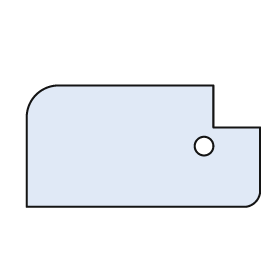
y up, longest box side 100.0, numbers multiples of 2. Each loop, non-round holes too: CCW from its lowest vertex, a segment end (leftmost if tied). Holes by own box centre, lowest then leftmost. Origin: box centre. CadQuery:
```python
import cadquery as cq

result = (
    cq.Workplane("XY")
    .moveTo(-50.0, -26.0)
    .lineTo(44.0, -26.0)
    .threePointArc((48.0, -24.0), (50.0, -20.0))
    .lineTo(50.0, 8.0)
    .lineTo(30.0, 8.0)
    .lineTo(30.0, 26.0)
    .lineTo(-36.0, 26.0)
    .threePointArc((-46.0, 22.0), (-50.0, 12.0))
    .close()
    .moveTo(26.0, 0.0)
    .circle(4.0)
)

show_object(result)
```